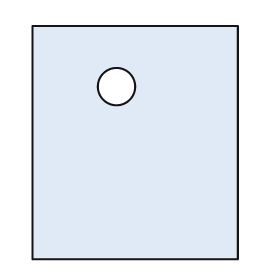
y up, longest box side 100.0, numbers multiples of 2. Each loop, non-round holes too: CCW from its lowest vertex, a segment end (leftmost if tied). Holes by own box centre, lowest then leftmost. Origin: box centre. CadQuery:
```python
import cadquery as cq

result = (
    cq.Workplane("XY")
    .moveTo(-44.0, -50.0)
    .lineTo(44.0, -50.0)
    .lineTo(44.0, 50.0)
    .lineTo(-44.0, 50.0)
    .close()
    .moveTo(-8.0, 24.0)
    .circle(8.0)
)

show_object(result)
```